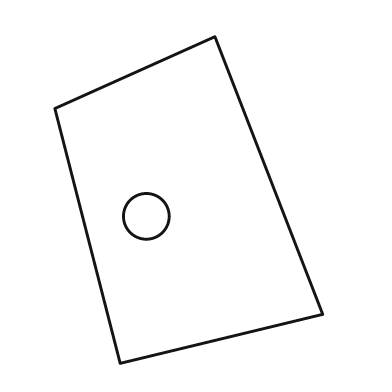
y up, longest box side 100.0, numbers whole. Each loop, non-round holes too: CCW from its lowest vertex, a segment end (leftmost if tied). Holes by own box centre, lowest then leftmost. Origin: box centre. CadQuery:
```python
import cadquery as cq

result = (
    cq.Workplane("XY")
    .moveTo(-21.0, -50.0)
    .lineTo(41.0, -35.0)
    .lineTo(8.0, 50.0)
    .lineTo(-41.0, 28.0)
    .close()
    .moveTo(-13.0, -5.0)
    .circle(7.0)
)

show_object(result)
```